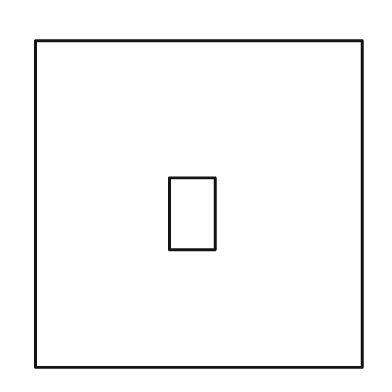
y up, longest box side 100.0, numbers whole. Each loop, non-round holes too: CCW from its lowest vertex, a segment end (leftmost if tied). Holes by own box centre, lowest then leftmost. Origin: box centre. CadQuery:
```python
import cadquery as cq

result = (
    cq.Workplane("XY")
    .moveTo(-50.0, -50.0)
    .lineTo(50.0, -50.0)
    .lineTo(50.0, 50.0)
    .lineTo(-50.0, 50.0)
    .close()
    .moveTo(-9.0, -14.0)
    .lineTo(5.0, -14.0)
    .lineTo(5.0, 8.0)
    .lineTo(-9.0, 8.0)
    .close()
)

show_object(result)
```